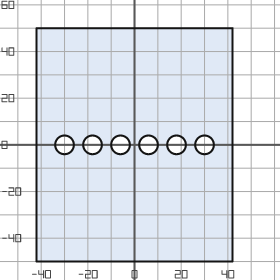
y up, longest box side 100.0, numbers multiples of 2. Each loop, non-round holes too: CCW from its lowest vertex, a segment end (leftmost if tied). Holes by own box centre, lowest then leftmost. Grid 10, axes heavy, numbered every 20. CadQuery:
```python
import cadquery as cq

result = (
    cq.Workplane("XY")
    .moveTo(-42.0, -50.0)
    .lineTo(42.0, -50.0)
    .lineTo(42.0, 50.0)
    .lineTo(-42.0, 50.0)
    .close()
    .moveTo(-30.0, 0.0)
    .circle(4.0)
    .moveTo(-18.0, 0.0)
    .circle(4.0)
    .moveTo(-6.0, 0.0)
    .circle(4.0)
    .moveTo(6.0, 0.0)
    .circle(4.0)
    .moveTo(18.0, 0.0)
    .circle(4.0)
    .moveTo(30.0, 0.0)
    .circle(4.0)
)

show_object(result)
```